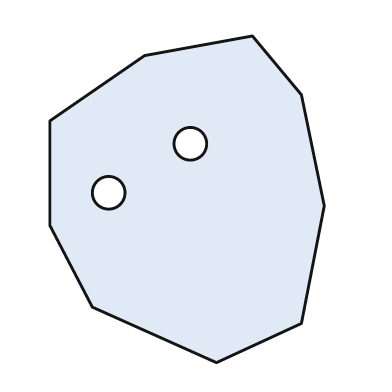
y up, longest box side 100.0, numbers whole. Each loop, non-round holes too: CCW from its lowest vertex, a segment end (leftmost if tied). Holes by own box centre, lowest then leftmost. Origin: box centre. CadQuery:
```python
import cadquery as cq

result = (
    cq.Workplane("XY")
    .moveTo(9.0, -50.0)
    .lineTo(35.0, -38.0)
    .lineTo(42.0, -2.0)
    .lineTo(35.0, 32.0)
    .lineTo(20.0, 50.0)
    .lineTo(-13.0, 44.0)
    .lineTo(-42.0, 24.0)
    .lineTo(-42.0, -8.0)
    .lineTo(-29.0, -33.0)
    .close()
    .moveTo(-24.0, 2.0)
    .circle(5.0)
    .moveTo(1.0, 17.0)
    .circle(5.0)
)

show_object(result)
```